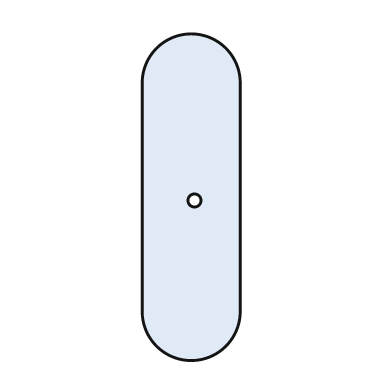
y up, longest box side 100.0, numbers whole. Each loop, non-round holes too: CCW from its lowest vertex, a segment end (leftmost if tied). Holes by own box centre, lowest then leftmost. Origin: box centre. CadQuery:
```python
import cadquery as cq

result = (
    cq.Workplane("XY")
    .moveTo(-15.0, -35.0)
    .threePointArc((0.0, -50.0), (15.0, -35.0))
    .lineTo(15.0, 35.0)
    .threePointArc((0.0, 50.0), (-15.0, 35.0))
    .close()
    .moveTo(1.0, -1.0)
    .circle(2.0)
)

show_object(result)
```